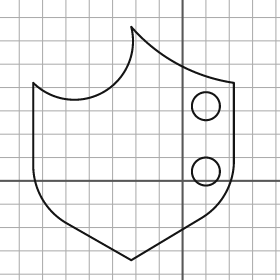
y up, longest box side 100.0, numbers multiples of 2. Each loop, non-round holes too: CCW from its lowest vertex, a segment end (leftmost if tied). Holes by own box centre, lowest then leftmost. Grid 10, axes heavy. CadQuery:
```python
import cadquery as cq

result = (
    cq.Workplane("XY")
    .moveTo(-22.0, -34.0)
    .lineTo(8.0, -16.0)
    .threePointArc((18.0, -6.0), (22.0, 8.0))
    .lineTo(22.0, 42.0)
    .threePointArc((-2.0, 50.0), (-22.0, 66.0))
    .threePointArc((-34.0, 38.0), (-64.0, 42.0))
    .lineTo(-64.0, 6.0)
    .threePointArc((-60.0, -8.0), (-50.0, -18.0))
    .close()
    .moveTo(10.0, 4.0)
    .circle(6.0)
    .moveTo(10.0, 32.0)
    .circle(6.0)
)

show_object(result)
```